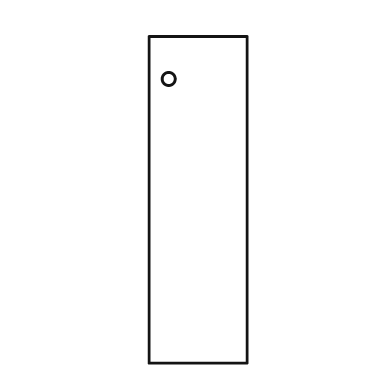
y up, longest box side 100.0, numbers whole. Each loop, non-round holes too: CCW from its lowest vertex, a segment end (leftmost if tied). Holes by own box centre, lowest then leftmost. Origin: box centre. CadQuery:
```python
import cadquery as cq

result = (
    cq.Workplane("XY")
    .moveTo(-15.0, -50.0)
    .lineTo(15.0, -50.0)
    .lineTo(15.0, 50.0)
    .lineTo(-15.0, 50.0)
    .close()
    .moveTo(-9.0, 37.0)
    .circle(2.0)
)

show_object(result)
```